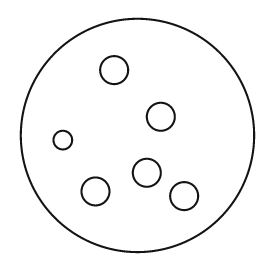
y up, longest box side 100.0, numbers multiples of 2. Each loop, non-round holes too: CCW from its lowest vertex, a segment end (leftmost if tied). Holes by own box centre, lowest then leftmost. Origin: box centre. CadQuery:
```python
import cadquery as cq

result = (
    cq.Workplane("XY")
    .moveTo(0.0, 0.0)
    .circle(50.0)
    .moveTo(20.0, -26.0)
    .circle(6.0)
    .moveTo(-18.0, -24.0)
    .circle(6.0)
    .moveTo(4.0, -16.0)
    .circle(6.0)
    .moveTo(-32.0, -2.0)
    .circle(4.0)
    .moveTo(10.0, 8.0)
    .circle(6.0)
    .moveTo(-10.0, 28.0)
    .circle(6.0)
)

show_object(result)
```